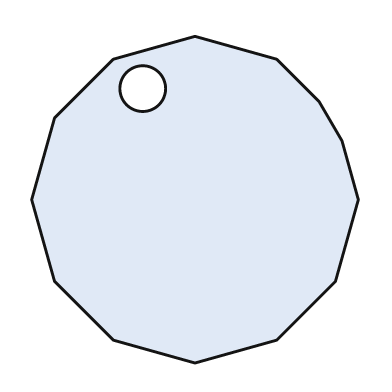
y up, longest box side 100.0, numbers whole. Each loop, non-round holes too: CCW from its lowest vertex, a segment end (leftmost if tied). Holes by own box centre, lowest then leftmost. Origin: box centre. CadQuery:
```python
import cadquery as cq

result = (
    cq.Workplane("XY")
    .moveTo(0.0, -50.0)
    .lineTo(25.0, -43.0)
    .lineTo(43.0, -25.0)
    .lineTo(50.0, 0.0)
    .lineTo(45.0, 18.0)
    .lineTo(38.0, 30.0)
    .lineTo(25.0, 43.0)
    .lineTo(0.0, 50.0)
    .lineTo(-25.0, 43.0)
    .lineTo(-43.0, 25.0)
    .lineTo(-50.0, 0.0)
    .lineTo(-43.0, -25.0)
    .lineTo(-25.0, -43.0)
    .close()
    .moveTo(-16.0, 34.0)
    .circle(7.0)
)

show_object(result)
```